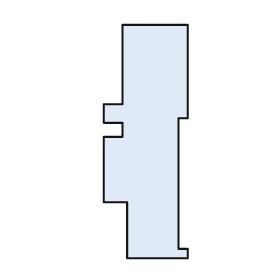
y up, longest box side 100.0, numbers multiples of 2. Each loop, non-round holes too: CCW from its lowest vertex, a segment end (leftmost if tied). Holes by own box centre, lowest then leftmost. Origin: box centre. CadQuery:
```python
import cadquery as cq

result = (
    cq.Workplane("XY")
    .moveTo(-8.0, -50.0)
    .lineTo(18.0, -50.0)
    .lineTo(18.0, -46.0)
    .lineTo(14.0, -46.0)
    .lineTo(14.0, 10.0)
    .lineTo(18.0, 10.0)
    .lineTo(18.0, 50.0)
    .lineTo(-10.0, 50.0)
    .lineTo(-10.0, 16.0)
    .lineTo(-18.0, 16.0)
    .lineTo(-18.0, 8.0)
    .lineTo(-10.0, 8.0)
    .lineTo(-10.0, 2.0)
    .lineTo(-18.0, 2.0)
    .lineTo(-18.0, -26.0)
    .lineTo(-8.0, -26.0)
    .close()
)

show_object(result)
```